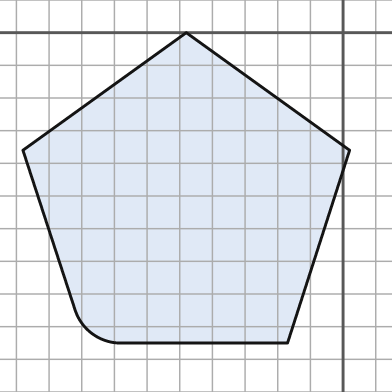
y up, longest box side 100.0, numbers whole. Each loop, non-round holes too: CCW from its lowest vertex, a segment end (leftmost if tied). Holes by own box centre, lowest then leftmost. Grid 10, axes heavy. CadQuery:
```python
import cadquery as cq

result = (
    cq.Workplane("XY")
    .moveTo(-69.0, -95.0)
    .lineTo(-17.0, -95.0)
    .lineTo(2.0, -36.0)
    .lineTo(-48.0, 0.0)
    .lineTo(-98.0, -36.0)
    .lineTo(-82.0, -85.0)
    .threePointArc((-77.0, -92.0), (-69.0, -95.0))
    .close()
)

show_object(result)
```